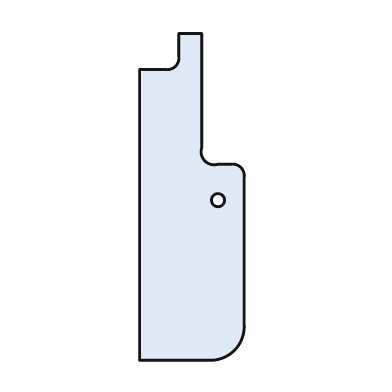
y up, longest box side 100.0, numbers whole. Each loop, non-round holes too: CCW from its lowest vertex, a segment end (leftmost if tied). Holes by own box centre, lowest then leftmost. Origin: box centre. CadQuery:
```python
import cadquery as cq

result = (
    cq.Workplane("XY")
    .moveTo(-16.0, -50.0)
    .lineTo(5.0, -50.0)
    .threePointArc((13.0, -47.0), (16.0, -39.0))
    .lineTo(16.0, 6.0)
    .threePointArc((15.0, 9.0), (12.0, 10.0))
    .lineTo(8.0, 10.0)
    .threePointArc((4.0, 11.0), (3.0, 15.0))
    .lineTo(3.0, 50.0)
    .lineTo(-4.0, 50.0)
    .lineTo(-4.0, 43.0)
    .threePointArc((-5.0, 40.0), (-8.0, 39.0))
    .lineTo(-16.0, 39.0)
    .close()
    .moveTo(8.0, -1.0)
    .circle(2.0)
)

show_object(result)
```